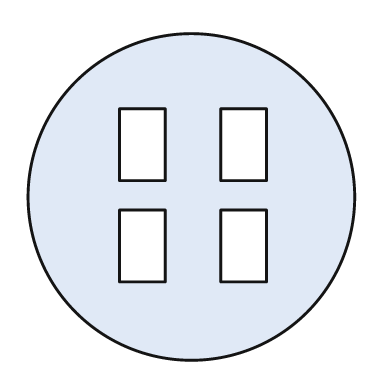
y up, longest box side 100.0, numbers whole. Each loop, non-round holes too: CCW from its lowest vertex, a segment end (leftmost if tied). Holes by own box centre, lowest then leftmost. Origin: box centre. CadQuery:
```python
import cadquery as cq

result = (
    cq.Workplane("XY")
    .moveTo(0.0, 0.0)
    .circle(50.0)
    .moveTo(-22.0, -26.0)
    .lineTo(-8.0, -26.0)
    .lineTo(-8.0, -4.0)
    .lineTo(-22.0, -4.0)
    .close()
    .moveTo(9.0, -26.0)
    .lineTo(23.0, -26.0)
    .lineTo(23.0, -4.0)
    .lineTo(9.0, -4.0)
    .close()
    .moveTo(-22.0, 5.0)
    .lineTo(-8.0, 5.0)
    .lineTo(-8.0, 27.0)
    .lineTo(-22.0, 27.0)
    .close()
    .moveTo(9.0, 5.0)
    .lineTo(23.0, 5.0)
    .lineTo(23.0, 27.0)
    .lineTo(9.0, 27.0)
    .close()
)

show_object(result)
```